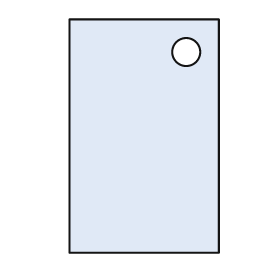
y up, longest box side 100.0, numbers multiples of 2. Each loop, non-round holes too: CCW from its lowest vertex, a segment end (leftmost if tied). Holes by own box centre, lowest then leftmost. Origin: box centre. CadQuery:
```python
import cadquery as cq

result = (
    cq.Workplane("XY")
    .moveTo(-32.0, -50.0)
    .lineTo(32.0, -50.0)
    .lineTo(32.0, 50.0)
    .lineTo(-32.0, 50.0)
    .close()
    .moveTo(18.0, 36.0)
    .circle(6.0)
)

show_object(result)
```